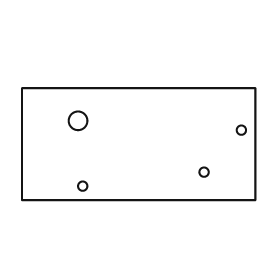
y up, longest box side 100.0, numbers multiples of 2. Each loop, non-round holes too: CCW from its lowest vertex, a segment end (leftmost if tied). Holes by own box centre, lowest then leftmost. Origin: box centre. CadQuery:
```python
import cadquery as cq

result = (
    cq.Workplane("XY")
    .moveTo(-50.0, -24.0)
    .lineTo(50.0, -24.0)
    .lineTo(50.0, 24.0)
    .lineTo(-50.0, 24.0)
    .close()
    .moveTo(-24.0, -18.0)
    .circle(2.0)
    .moveTo(28.0, -12.0)
    .circle(2.0)
    .moveTo(44.0, 6.0)
    .circle(2.0)
    .moveTo(-26.0, 10.0)
    .circle(4.0)
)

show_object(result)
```